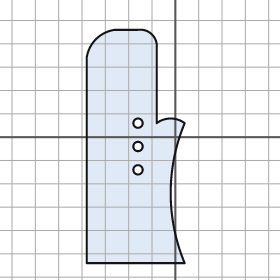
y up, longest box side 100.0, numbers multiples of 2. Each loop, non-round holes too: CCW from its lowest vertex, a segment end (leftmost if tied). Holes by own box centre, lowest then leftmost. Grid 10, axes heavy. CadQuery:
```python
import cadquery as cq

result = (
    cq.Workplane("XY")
    .moveTo(-38.0, -54.0)
    .lineTo(4.0, -54.0)
    .threePointArc((-2.0, -24.0), (4.0, 6.0))
    .threePointArc((-2.0, 8.0), (-8.0, 6.0))
    .lineTo(-8.0, 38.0)
    .threePointArc((-10.0, 44.0), (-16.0, 46.0))
    .lineTo(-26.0, 46.0)
    .threePointArc((-34.0, 42.0), (-38.0, 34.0))
    .close()
    .moveTo(-16.0, -14.0)
    .circle(2.0)
    .moveTo(-16.0, -4.0)
    .circle(2.0)
    .moveTo(-16.0, 6.0)
    .circle(2.0)
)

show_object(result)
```